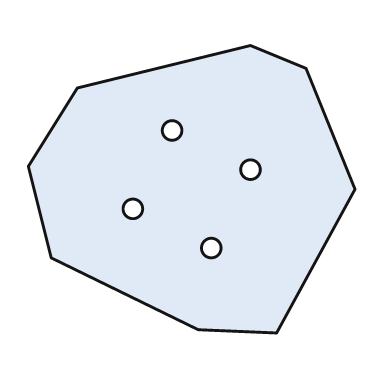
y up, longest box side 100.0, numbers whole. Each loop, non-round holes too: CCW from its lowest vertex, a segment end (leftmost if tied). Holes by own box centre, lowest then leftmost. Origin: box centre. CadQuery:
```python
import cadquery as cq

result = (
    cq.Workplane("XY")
    .moveTo(26.0, -44.0)
    .lineTo(50.0, 0.0)
    .lineTo(35.0, 37.0)
    .lineTo(18.0, 44.0)
    .lineTo(-35.0, 31.0)
    .lineTo(-50.0, 7.0)
    .lineTo(-43.0, -21.0)
    .lineTo(2.0, -43.0)
    .close()
    .moveTo(6.0, -18.0)
    .circle(3.0)
    .moveTo(-18.0, -6.0)
    .circle(3.0)
    .moveTo(18.0, 6.0)
    .circle(3.0)
    .moveTo(-6.0, 18.0)
    .circle(3.0)
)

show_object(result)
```